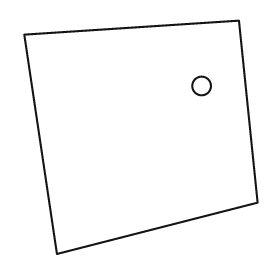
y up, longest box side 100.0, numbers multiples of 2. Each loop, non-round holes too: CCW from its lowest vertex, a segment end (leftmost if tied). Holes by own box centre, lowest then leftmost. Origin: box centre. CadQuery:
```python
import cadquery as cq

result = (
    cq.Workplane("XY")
    .moveTo(-36.0, -50.0)
    .lineTo(50.0, -28.0)
    .lineTo(42.0, 50.0)
    .lineTo(-50.0, 44.0)
    .close()
    .moveTo(26.0, 22.0)
    .circle(4.0)
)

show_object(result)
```